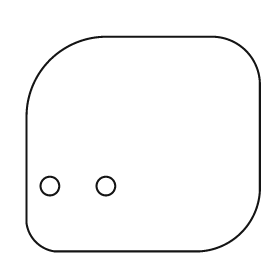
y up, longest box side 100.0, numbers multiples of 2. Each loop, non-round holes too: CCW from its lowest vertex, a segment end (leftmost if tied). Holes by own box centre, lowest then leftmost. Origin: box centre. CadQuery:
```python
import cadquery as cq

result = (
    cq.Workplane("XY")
    .moveTo(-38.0, -46.0)
    .lineTo(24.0, -46.0)
    .threePointArc((42.0, -38.0), (50.0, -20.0))
    .lineTo(50.0, 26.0)
    .threePointArc((44.0, 40.0), (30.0, 46.0))
    .lineTo(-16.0, 46.0)
    .threePointArc((-40.0, 36.0), (-50.0, 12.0))
    .lineTo(-50.0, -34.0)
    .threePointArc((-46.0, -42.0), (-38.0, -46.0))
    .close()
    .moveTo(-40.0, -18.0)
    .circle(4.0)
    .moveTo(-16.0, -18.0)
    .circle(4.0)
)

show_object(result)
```